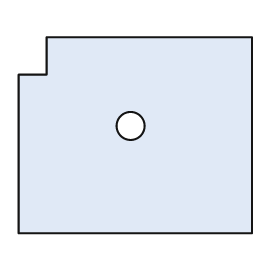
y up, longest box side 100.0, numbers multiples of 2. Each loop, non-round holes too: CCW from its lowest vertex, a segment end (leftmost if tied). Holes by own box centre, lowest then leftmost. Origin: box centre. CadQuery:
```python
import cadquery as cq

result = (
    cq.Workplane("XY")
    .moveTo(-50.0, -42.0)
    .lineTo(50.0, -42.0)
    .lineTo(50.0, 42.0)
    .lineTo(-38.0, 42.0)
    .lineTo(-38.0, 26.0)
    .lineTo(-50.0, 26.0)
    .close()
    .moveTo(-2.0, 4.0)
    .circle(6.0)
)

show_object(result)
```